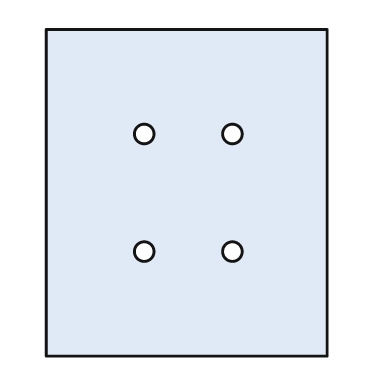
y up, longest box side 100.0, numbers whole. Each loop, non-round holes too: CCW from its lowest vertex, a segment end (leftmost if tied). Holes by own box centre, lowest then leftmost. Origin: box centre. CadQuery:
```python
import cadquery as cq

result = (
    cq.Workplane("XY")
    .moveTo(-43.0, -50.0)
    .lineTo(43.0, -50.0)
    .lineTo(43.0, 50.0)
    .lineTo(-43.0, 50.0)
    .close()
    .moveTo(-13.0, -18.0)
    .circle(3.0)
    .moveTo(14.0, -18.0)
    .circle(3.0)
    .moveTo(-13.0, 18.0)
    .circle(3.0)
    .moveTo(14.0, 18.0)
    .circle(3.0)
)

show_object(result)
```